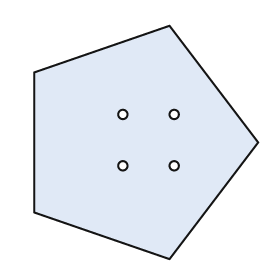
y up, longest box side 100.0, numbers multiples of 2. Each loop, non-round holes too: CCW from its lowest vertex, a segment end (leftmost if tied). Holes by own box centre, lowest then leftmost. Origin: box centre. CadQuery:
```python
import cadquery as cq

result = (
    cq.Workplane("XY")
    .moveTo(10.0, -50.0)
    .lineTo(48.0, 0.0)
    .lineTo(10.0, 50.0)
    .lineTo(-48.0, 30.0)
    .lineTo(-48.0, -30.0)
    .close()
    .moveTo(-10.0, -10.0)
    .circle(2.0)
    .moveTo(12.0, -10.0)
    .circle(2.0)
    .moveTo(-10.0, 12.0)
    .circle(2.0)
    .moveTo(12.0, 12.0)
    .circle(2.0)
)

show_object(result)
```